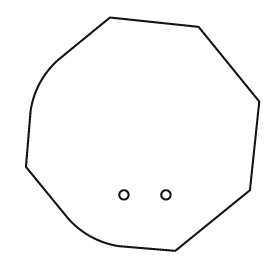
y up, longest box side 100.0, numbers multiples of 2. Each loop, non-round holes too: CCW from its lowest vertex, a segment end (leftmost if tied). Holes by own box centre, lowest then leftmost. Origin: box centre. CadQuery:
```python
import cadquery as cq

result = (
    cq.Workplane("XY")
    .moveTo(14.0, -50.0)
    .lineTo(46.0, -24.0)
    .lineTo(50.0, 14.0)
    .lineTo(24.0, 46.0)
    .lineTo(-14.0, 50.0)
    .lineTo(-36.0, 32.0)
    .threePointArc((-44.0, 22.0), (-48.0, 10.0))
    .lineTo(-50.0, -14.0)
    .lineTo(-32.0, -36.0)
    .threePointArc((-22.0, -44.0), (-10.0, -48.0))
    .close()
    .moveTo(-8.0, -26.0)
    .circle(2.0)
    .moveTo(10.0, -26.0)
    .circle(2.0)
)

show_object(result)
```